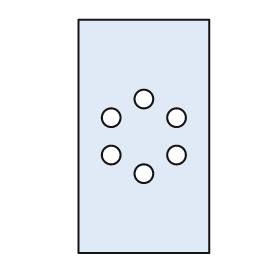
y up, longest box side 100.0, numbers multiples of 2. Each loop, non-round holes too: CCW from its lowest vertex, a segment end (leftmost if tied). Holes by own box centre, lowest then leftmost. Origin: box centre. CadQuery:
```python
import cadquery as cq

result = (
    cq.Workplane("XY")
    .moveTo(-28.0, -50.0)
    .lineTo(28.0, -50.0)
    .lineTo(28.0, 50.0)
    .lineTo(-28.0, 50.0)
    .close()
    .moveTo(0.0, -16.0)
    .circle(4.0)
    .moveTo(-14.0, -8.0)
    .circle(4.0)
    .moveTo(14.0, -8.0)
    .circle(4.0)
    .moveTo(-14.0, 8.0)
    .circle(4.0)
    .moveTo(14.0, 8.0)
    .circle(4.0)
    .moveTo(0.0, 16.0)
    .circle(4.0)
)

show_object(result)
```